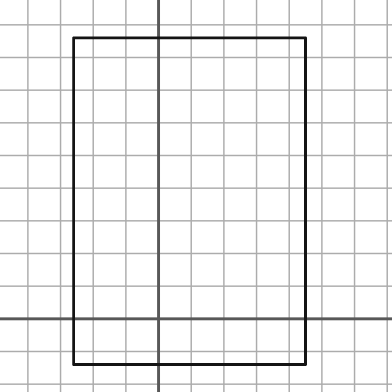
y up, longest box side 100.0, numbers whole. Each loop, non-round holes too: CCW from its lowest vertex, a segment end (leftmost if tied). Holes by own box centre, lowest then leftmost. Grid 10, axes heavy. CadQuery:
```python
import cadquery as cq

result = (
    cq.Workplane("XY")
    .moveTo(-26.0, -14.0)
    .lineTo(45.0, -14.0)
    .lineTo(45.0, 86.0)
    .lineTo(-26.0, 86.0)
    .close()
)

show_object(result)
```